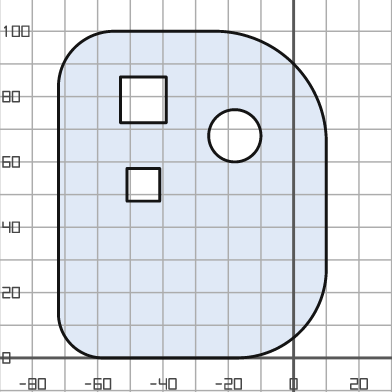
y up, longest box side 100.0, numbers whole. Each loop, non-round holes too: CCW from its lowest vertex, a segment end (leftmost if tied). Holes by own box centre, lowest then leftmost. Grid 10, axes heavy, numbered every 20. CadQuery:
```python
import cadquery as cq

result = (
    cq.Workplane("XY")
    .moveTo(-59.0, 0.0)
    .lineTo(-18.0, 0.0)
    .threePointArc((2.0, 8.0), (10.0, 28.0))
    .lineTo(10.0, 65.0)
    .threePointArc((0.0, 90.0), (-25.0, 100.0))
    .lineTo(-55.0, 100.0)
    .threePointArc((-67.0, 95.0), (-72.0, 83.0))
    .lineTo(-72.0, 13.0)
    .threePointArc((-68.0, 4.0), (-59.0, 0.0))
    .close()
    .moveTo(-51.0, 48.0)
    .lineTo(-41.0, 48.0)
    .lineTo(-41.0, 58.0)
    .lineTo(-51.0, 58.0)
    .close()
    .moveTo(-18.0, 68.0)
    .circle(8.0)
    .moveTo(-53.0, 72.0)
    .lineTo(-39.0, 72.0)
    .lineTo(-39.0, 86.0)
    .lineTo(-53.0, 86.0)
    .close()
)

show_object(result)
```